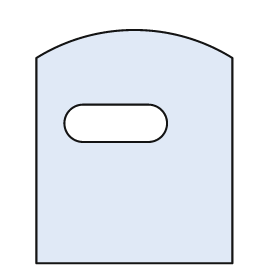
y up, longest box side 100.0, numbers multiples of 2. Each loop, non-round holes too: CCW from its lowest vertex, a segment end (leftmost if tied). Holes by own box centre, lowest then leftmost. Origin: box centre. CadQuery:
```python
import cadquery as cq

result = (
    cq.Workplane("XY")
    .moveTo(-42.0, -50.0)
    .lineTo(42.0, -50.0)
    .lineTo(42.0, 38.0)
    .threePointArc((0.0, 50.0), (-42.0, 38.0))
    .close()
    .moveTo(-22.0, 2.0)
    .lineTo(6.0, 2.0)
    .threePointArc((14.0, 10.0), (6.0, 18.0))
    .lineTo(-22.0, 18.0)
    .threePointArc((-30.0, 10.0), (-22.0, 2.0))
    .close()
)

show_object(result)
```